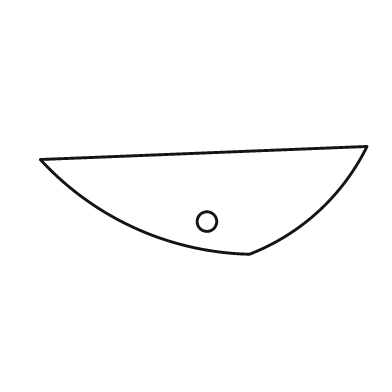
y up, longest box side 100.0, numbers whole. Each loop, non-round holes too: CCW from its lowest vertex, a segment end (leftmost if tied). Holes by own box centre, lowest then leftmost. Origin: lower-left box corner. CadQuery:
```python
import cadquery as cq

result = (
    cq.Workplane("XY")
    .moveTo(64.0, 0.0)
    .threePointArc((85.0, 13.0), (100.0, 33.0))
    .lineTo(0.0, 29.0)
    .threePointArc((29.0, 8.0), (64.0, 0.0))
    .close()
    .moveTo(51.0, 10.0)
    .circle(3.0)
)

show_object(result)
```